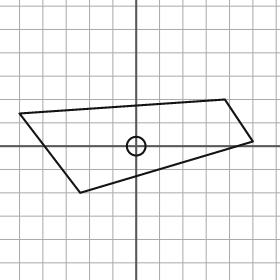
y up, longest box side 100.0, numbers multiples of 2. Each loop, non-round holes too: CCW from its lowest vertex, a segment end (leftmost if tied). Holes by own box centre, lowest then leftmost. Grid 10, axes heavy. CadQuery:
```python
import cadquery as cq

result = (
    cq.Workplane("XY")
    .moveTo(-24.0, -20.0)
    .lineTo(50.0, 2.0)
    .lineTo(38.0, 20.0)
    .lineTo(-50.0, 14.0)
    .close()
    .moveTo(0.0, 0.0)
    .circle(4.0)
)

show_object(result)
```